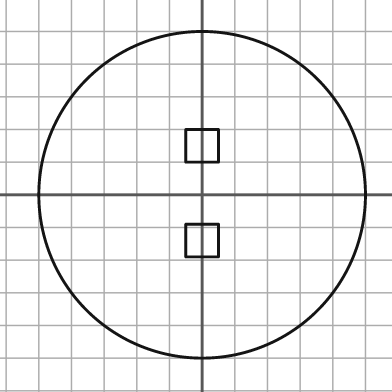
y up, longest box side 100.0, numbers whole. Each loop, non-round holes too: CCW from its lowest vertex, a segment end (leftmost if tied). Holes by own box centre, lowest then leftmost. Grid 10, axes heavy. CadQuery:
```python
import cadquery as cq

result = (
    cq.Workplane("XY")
    .moveTo(0.0, 0.0)
    .circle(50.0)
    .moveTo(-5.0, -19.0)
    .lineTo(5.0, -19.0)
    .lineTo(5.0, -9.0)
    .lineTo(-5.0, -9.0)
    .close()
    .moveTo(-5.0, 10.0)
    .lineTo(5.0, 10.0)
    .lineTo(5.0, 20.0)
    .lineTo(-5.0, 20.0)
    .close()
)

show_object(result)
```